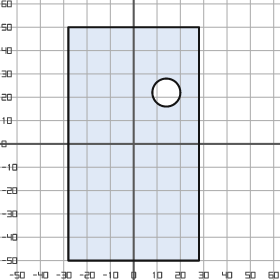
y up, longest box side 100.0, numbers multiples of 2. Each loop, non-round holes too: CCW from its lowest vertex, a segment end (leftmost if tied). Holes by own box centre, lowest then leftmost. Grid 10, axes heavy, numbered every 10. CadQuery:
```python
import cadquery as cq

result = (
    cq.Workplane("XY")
    .moveTo(-28.0, -50.0)
    .lineTo(28.0, -50.0)
    .lineTo(28.0, 50.0)
    .lineTo(-28.0, 50.0)
    .close()
    .moveTo(14.0, 22.0)
    .circle(6.0)
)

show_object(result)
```